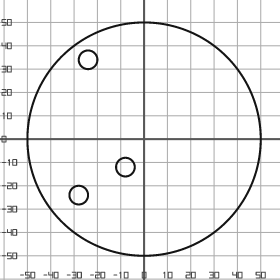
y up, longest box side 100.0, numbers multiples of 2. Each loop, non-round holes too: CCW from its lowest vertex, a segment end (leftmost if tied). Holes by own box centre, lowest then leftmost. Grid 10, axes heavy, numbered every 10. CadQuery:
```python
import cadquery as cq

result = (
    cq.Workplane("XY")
    .moveTo(0.0, 0.0)
    .circle(50.0)
    .moveTo(-28.0, -24.0)
    .circle(4.0)
    .moveTo(-8.0, -12.0)
    .circle(4.0)
    .moveTo(-24.0, 34.0)
    .circle(4.0)
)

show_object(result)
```